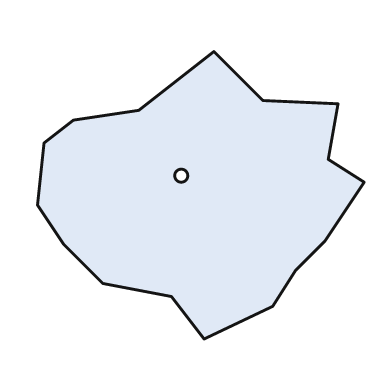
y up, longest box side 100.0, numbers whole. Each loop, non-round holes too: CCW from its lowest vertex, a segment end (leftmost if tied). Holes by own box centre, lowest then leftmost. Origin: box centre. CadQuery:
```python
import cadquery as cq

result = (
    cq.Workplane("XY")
    .moveTo(1.0, -44.0)
    .lineTo(22.0, -34.0)
    .lineTo(29.0, -23.0)
    .lineTo(38.0, -14.0)
    .lineTo(50.0, 4.0)
    .lineTo(39.0, 11.0)
    .lineTo(42.0, 28.0)
    .lineTo(19.0, 29.0)
    .lineTo(4.0, 44.0)
    .lineTo(-19.0, 26.0)
    .lineTo(-39.0, 23.0)
    .lineTo(-48.0, 16.0)
    .lineTo(-50.0, -3.0)
    .lineTo(-42.0, -15.0)
    .lineTo(-30.0, -27.0)
    .lineTo(-9.0, -31.0)
    .close()
    .moveTo(-6.0, 6.0)
    .circle(2.0)
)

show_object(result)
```